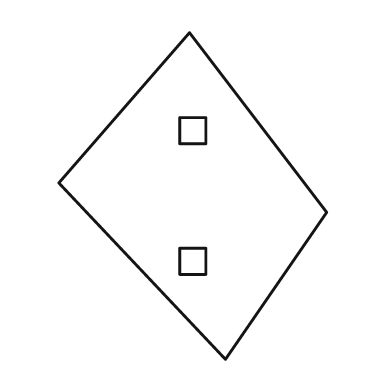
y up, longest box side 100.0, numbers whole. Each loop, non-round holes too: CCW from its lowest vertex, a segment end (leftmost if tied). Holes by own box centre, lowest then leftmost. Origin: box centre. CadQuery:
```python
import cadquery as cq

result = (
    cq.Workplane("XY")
    .moveTo(10.0, -50.0)
    .lineTo(41.0, -5.0)
    .lineTo(-1.0, 50.0)
    .lineTo(-41.0, 4.0)
    .close()
    .moveTo(-4.0, -24.0)
    .lineTo(4.0, -24.0)
    .lineTo(4.0, -16.0)
    .lineTo(-4.0, -16.0)
    .close()
    .moveTo(-4.0, 16.0)
    .lineTo(4.0, 16.0)
    .lineTo(4.0, 24.0)
    .lineTo(-4.0, 24.0)
    .close()
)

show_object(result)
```